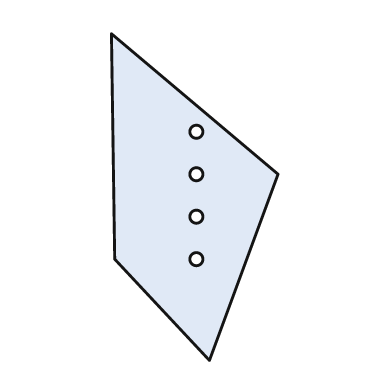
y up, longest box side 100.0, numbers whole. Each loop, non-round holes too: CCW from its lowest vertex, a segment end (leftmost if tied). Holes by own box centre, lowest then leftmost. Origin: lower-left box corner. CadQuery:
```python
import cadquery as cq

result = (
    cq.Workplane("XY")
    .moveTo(30.0, 0.0)
    .lineTo(51.0, 57.0)
    .lineTo(0.0, 100.0)
    .lineTo(1.0, 31.0)
    .close()
    .moveTo(26.0, 31.0)
    .circle(2.0)
    .moveTo(26.0, 44.0)
    .circle(2.0)
    .moveTo(26.0, 57.0)
    .circle(2.0)
    .moveTo(26.0, 70.0)
    .circle(2.0)
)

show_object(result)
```